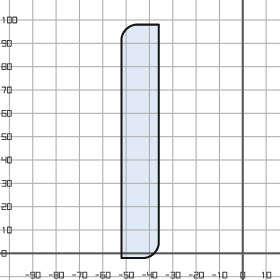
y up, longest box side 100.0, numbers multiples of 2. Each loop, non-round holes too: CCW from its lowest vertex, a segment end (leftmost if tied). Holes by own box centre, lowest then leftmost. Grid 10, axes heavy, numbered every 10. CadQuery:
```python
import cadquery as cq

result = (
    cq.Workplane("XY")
    .moveTo(-52.0, -2.0)
    .lineTo(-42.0, -2.0)
    .threePointArc((-38.0, 0.0), (-36.0, 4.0))
    .lineTo(-36.0, 98.0)
    .lineTo(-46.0, 98.0)
    .threePointArc((-50.0, 96.0), (-52.0, 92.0))
    .close()
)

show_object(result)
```